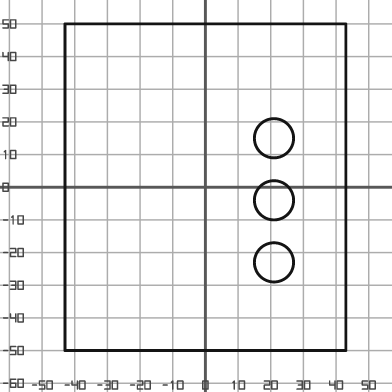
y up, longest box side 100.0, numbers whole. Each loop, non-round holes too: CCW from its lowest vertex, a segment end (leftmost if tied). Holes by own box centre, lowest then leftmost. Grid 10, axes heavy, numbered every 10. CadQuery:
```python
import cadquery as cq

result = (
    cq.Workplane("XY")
    .moveTo(-43.0, -50.0)
    .lineTo(43.0, -50.0)
    .lineTo(43.0, 50.0)
    .lineTo(-43.0, 50.0)
    .close()
    .moveTo(21.0, -23.0)
    .circle(6.0)
    .moveTo(21.0, -4.0)
    .circle(6.0)
    .moveTo(21.0, 15.0)
    .circle(6.0)
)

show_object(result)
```